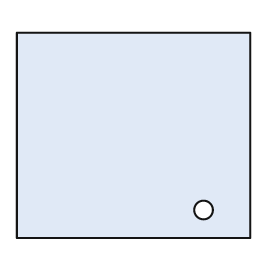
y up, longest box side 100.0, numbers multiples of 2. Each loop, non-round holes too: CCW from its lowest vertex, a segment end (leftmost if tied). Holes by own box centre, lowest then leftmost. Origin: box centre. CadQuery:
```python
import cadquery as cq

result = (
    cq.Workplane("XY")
    .moveTo(-50.0, -44.0)
    .lineTo(50.0, -44.0)
    .lineTo(50.0, 44.0)
    .lineTo(-50.0, 44.0)
    .close()
    .moveTo(30.0, -32.0)
    .circle(4.0)
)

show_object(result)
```